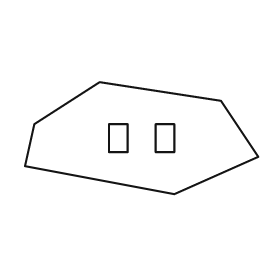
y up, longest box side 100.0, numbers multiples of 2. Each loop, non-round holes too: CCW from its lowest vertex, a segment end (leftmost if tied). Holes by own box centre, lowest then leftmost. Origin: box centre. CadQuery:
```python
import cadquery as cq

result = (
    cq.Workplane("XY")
    .moveTo(14.0, -24.0)
    .lineTo(50.0, -8.0)
    .lineTo(34.0, 16.0)
    .lineTo(-18.0, 24.0)
    .lineTo(-46.0, 6.0)
    .lineTo(-50.0, -12.0)
    .close()
    .moveTo(-14.0, -6.0)
    .lineTo(-6.0, -6.0)
    .lineTo(-6.0, 6.0)
    .lineTo(-14.0, 6.0)
    .close()
    .moveTo(6.0, -6.0)
    .lineTo(14.0, -6.0)
    .lineTo(14.0, 6.0)
    .lineTo(6.0, 6.0)
    .close()
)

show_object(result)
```